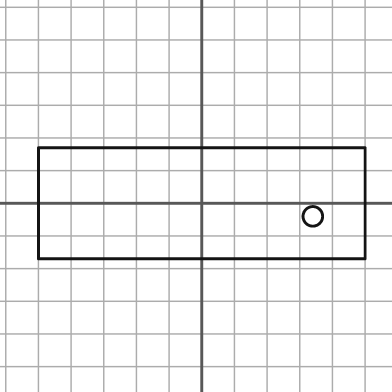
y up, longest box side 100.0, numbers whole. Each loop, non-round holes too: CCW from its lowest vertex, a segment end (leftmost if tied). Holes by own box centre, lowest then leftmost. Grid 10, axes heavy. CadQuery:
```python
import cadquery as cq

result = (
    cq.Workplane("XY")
    .moveTo(-50.0, -17.0)
    .lineTo(50.0, -17.0)
    .lineTo(50.0, 17.0)
    .lineTo(-50.0, 17.0)
    .close()
    .moveTo(34.0, -4.0)
    .circle(3.0)
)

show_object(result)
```